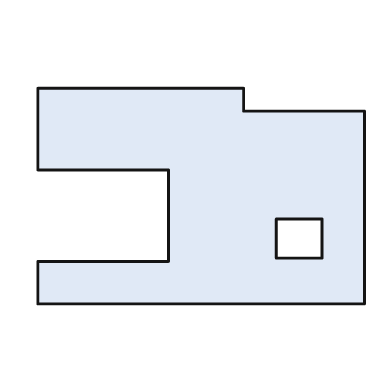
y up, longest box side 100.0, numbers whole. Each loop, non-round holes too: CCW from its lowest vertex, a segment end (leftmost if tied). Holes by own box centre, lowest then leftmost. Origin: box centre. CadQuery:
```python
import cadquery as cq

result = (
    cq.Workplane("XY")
    .moveTo(-50.0, -33.0)
    .lineTo(50.0, -33.0)
    .lineTo(50.0, 26.0)
    .lineTo(13.0, 26.0)
    .lineTo(13.0, 33.0)
    .lineTo(-50.0, 33.0)
    .lineTo(-50.0, 8.0)
    .lineTo(-10.0, 8.0)
    .lineTo(-10.0, -20.0)
    .lineTo(-50.0, -20.0)
    .close()
    .moveTo(23.0, -19.0)
    .lineTo(37.0, -19.0)
    .lineTo(37.0, -7.0)
    .lineTo(23.0, -7.0)
    .close()
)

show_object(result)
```